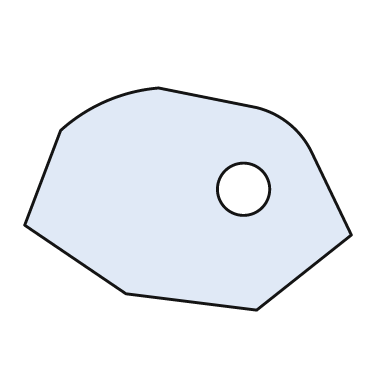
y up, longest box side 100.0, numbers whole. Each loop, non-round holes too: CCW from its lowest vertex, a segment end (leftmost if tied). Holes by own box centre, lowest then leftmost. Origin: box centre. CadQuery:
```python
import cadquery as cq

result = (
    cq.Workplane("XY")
    .moveTo(21.0, -34.0)
    .lineTo(50.0, -11.0)
    .lineTo(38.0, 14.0)
    .threePointArc((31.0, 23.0), (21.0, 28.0))
    .lineTo(-9.0, 34.0)
    .threePointArc((-25.0, 30.0), (-39.0, 21.0))
    .lineTo(-50.0, -8.0)
    .lineTo(-19.0, -29.0)
    .close()
    .moveTo(17.0, 3.0)
    .circle(8.0)
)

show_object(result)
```